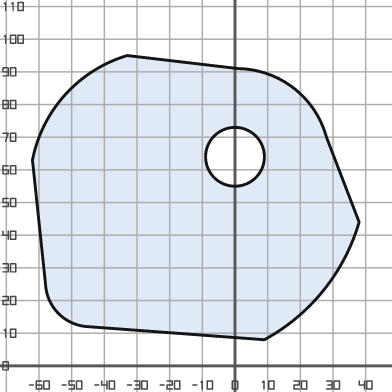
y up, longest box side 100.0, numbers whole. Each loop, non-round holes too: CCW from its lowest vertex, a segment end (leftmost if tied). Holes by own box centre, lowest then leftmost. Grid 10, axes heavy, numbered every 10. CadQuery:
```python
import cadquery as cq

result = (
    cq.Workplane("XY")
    .moveTo(9.0, 8.0)
    .threePointArc((27.0, 23.0), (38.0, 44.0))
    .lineTo(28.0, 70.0)
    .threePointArc((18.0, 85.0), (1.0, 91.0))
    .lineTo(-33.0, 95.0)
    .threePointArc((-52.0, 83.0), (-62.0, 63.0))
    .lineTo(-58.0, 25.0)
    .threePointArc((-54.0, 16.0), (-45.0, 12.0))
    .close()
    .moveTo(0.0, 64.0)
    .circle(9.0)
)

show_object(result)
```